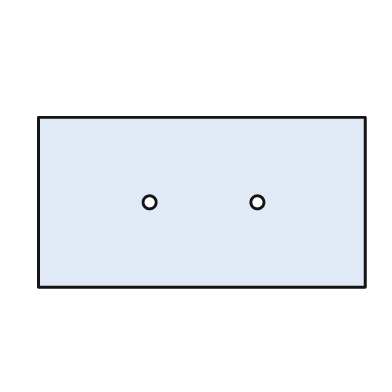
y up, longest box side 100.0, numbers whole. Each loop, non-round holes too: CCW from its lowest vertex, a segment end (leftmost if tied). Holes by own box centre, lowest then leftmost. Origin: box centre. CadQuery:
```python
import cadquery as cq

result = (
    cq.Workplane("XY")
    .moveTo(-50.0, -26.0)
    .lineTo(50.0, -26.0)
    .lineTo(50.0, 26.0)
    .lineTo(-50.0, 26.0)
    .close()
    .moveTo(-16.0, 0.0)
    .circle(2.0)
    .moveTo(17.0, 0.0)
    .circle(2.0)
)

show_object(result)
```